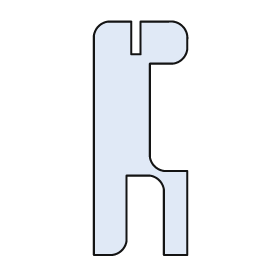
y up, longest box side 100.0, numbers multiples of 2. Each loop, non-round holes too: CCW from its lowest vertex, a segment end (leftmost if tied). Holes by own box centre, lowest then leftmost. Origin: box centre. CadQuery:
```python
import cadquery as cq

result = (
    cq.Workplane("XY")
    .moveTo(-20.0, -50.0)
    .lineTo(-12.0, -50.0)
    .threePointArc((-8.0, -48.0), (-6.0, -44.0))
    .lineTo(-6.0, -16.0)
    .lineTo(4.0, -16.0)
    .threePointArc((8.0, -18.0), (10.0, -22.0))
    .lineTo(10.0, -50.0)
    .lineTo(20.0, -50.0)
    .lineTo(20.0, -14.0)
    .lineTo(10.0, -14.0)
    .threePointArc((6.0, -12.0), (4.0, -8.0))
    .lineTo(4.0, 32.0)
    .lineTo(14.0, 32.0)
    .threePointArc((18.0, 34.0), (20.0, 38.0))
    .lineTo(20.0, 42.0)
    .threePointArc((18.0, 48.0), (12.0, 50.0))
    .lineTo(0.0, 50.0)
    .lineTo(0.0, 36.0)
    .lineTo(-4.0, 36.0)
    .lineTo(-4.0, 50.0)
    .lineTo(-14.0, 50.0)
    .threePointArc((-18.0, 48.0), (-20.0, 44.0))
    .close()
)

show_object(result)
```